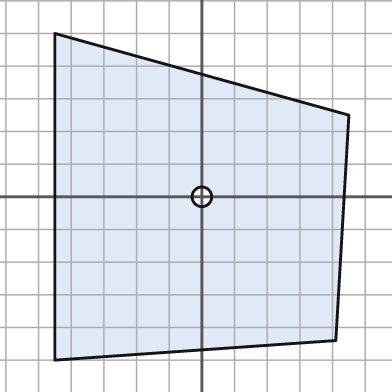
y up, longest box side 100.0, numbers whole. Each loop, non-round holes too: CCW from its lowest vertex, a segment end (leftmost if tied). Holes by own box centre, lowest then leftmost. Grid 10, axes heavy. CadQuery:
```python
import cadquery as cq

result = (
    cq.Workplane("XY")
    .moveTo(-45.0, -50.0)
    .lineTo(41.0, -44.0)
    .lineTo(45.0, 25.0)
    .lineTo(-45.0, 50.0)
    .close()
    .moveTo(0.0, 0.0)
    .circle(3.0)
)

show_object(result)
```